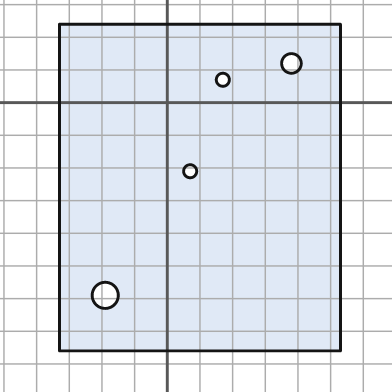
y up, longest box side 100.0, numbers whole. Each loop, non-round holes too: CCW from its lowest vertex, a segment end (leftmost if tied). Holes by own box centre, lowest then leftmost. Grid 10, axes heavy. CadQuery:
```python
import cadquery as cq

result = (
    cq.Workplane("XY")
    .moveTo(-33.0, -76.0)
    .lineTo(53.0, -76.0)
    .lineTo(53.0, 24.0)
    .lineTo(-33.0, 24.0)
    .close()
    .moveTo(-19.0, -59.0)
    .circle(4.0)
    .moveTo(7.0, -21.0)
    .circle(2.0)
    .moveTo(17.0, 7.0)
    .circle(2.0)
    .moveTo(38.0, 12.0)
    .circle(3.0)
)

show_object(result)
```